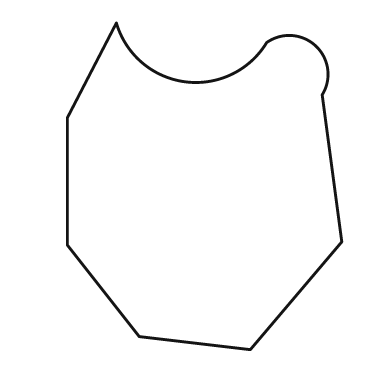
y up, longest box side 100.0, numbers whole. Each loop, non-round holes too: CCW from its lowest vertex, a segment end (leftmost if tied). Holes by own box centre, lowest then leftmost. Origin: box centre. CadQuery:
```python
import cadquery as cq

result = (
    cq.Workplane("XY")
    .moveTo(14.0, -50.0)
    .lineTo(42.0, -17.0)
    .lineTo(36.0, 28.0)
    .threePointArc((34.0, 43.0), (19.0, 44.0))
    .threePointArc((-6.0, 32.0), (-27.0, 50.0))
    .lineTo(-42.0, 21.0)
    .lineTo(-42.0, -18.0)
    .lineTo(-20.0, -46.0)
    .close()
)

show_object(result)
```